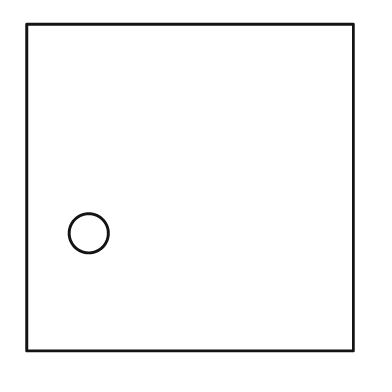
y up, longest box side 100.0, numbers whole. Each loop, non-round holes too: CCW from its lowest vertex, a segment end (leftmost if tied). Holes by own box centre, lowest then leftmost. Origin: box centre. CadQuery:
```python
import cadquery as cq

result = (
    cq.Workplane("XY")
    .moveTo(-50.0, -50.0)
    .lineTo(50.0, -50.0)
    .lineTo(50.0, 50.0)
    .lineTo(-50.0, 50.0)
    .close()
    .moveTo(-31.0, -14.0)
    .circle(6.0)
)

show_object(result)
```